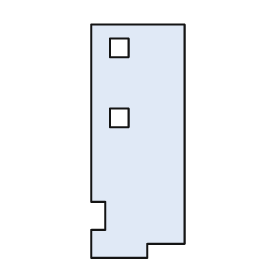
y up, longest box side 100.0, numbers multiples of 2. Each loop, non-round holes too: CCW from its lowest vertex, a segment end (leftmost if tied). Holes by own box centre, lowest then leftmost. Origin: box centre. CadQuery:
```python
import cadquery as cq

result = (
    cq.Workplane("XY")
    .moveTo(-20.0, -50.0)
    .lineTo(4.0, -50.0)
    .lineTo(4.0, -44.0)
    .lineTo(20.0, -44.0)
    .lineTo(20.0, 50.0)
    .lineTo(-20.0, 50.0)
    .lineTo(-20.0, -26.0)
    .lineTo(-14.0, -26.0)
    .lineTo(-14.0, -38.0)
    .lineTo(-20.0, -38.0)
    .close()
    .moveTo(-12.0, 6.0)
    .lineTo(-4.0, 6.0)
    .lineTo(-4.0, 14.0)
    .lineTo(-12.0, 14.0)
    .close()
    .moveTo(-12.0, 36.0)
    .lineTo(-4.0, 36.0)
    .lineTo(-4.0, 44.0)
    .lineTo(-12.0, 44.0)
    .close()
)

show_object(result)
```